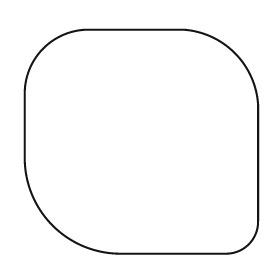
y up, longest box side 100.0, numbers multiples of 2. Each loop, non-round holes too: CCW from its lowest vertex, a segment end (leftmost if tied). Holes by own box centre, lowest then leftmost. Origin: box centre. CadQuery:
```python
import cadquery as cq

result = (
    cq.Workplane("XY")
    .moveTo(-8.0, -48.0)
    .lineTo(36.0, -48.0)
    .threePointArc((46.0, -44.0), (50.0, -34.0))
    .lineTo(50.0, 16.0)
    .threePointArc((40.0, 38.0), (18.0, 48.0))
    .lineTo(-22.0, 48.0)
    .threePointArc((-42.0, 40.0), (-50.0, 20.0))
    .lineTo(-50.0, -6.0)
    .threePointArc((-38.0, -36.0), (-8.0, -48.0))
    .close()
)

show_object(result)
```